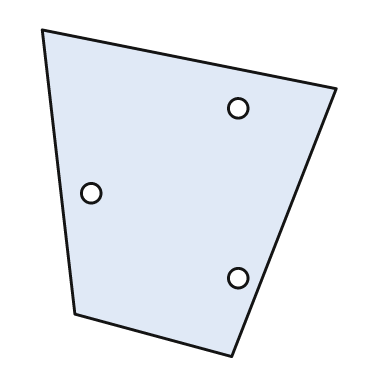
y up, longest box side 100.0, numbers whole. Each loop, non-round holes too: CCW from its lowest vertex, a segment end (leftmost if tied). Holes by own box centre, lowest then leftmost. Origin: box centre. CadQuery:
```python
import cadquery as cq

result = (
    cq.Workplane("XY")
    .moveTo(13.0, -50.0)
    .lineTo(45.0, 32.0)
    .lineTo(-45.0, 50.0)
    .lineTo(-35.0, -37.0)
    .close()
    .moveTo(15.0, -26.0)
    .circle(3.0)
    .moveTo(-30.0, 0.0)
    .circle(3.0)
    .moveTo(15.0, 26.0)
    .circle(3.0)
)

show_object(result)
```